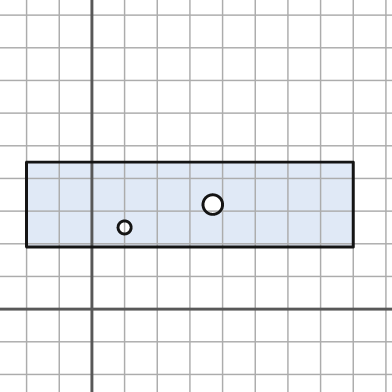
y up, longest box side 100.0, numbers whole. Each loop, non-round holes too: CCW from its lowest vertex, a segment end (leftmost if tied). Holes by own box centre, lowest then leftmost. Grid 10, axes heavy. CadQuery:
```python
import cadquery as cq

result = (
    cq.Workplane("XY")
    .moveTo(-20.0, 19.0)
    .lineTo(80.0, 19.0)
    .lineTo(80.0, 45.0)
    .lineTo(-20.0, 45.0)
    .close()
    .moveTo(10.0, 25.0)
    .circle(2.0)
    .moveTo(37.0, 32.0)
    .circle(3.0)
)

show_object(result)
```